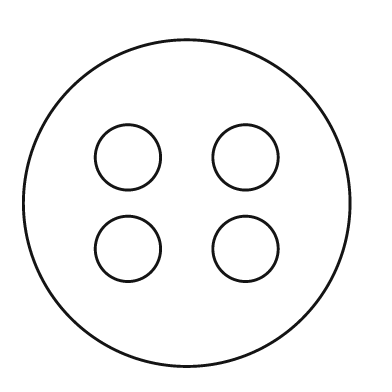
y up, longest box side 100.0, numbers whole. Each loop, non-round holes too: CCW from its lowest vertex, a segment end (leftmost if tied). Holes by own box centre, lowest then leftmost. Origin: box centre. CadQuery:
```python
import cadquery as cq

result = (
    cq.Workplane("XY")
    .moveTo(0.0, 0.0)
    .circle(50.0)
    .moveTo(-18.0, -14.0)
    .circle(10.0)
    .moveTo(18.0, -14.0)
    .circle(10.0)
    .moveTo(-18.0, 14.0)
    .circle(10.0)
    .moveTo(18.0, 14.0)
    .circle(10.0)
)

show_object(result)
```